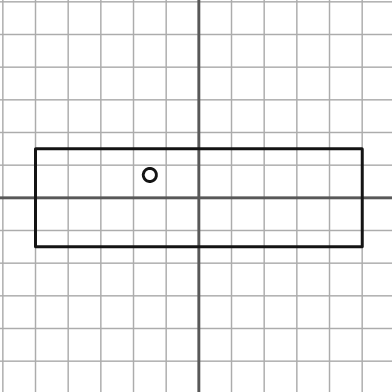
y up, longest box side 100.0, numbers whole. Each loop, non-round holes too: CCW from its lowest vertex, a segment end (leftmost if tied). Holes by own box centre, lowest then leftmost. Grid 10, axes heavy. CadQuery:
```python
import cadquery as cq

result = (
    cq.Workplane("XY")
    .moveTo(-50.0, -15.0)
    .lineTo(50.0, -15.0)
    .lineTo(50.0, 15.0)
    .lineTo(-50.0, 15.0)
    .close()
    .moveTo(-15.0, 7.0)
    .circle(2.0)
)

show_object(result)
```